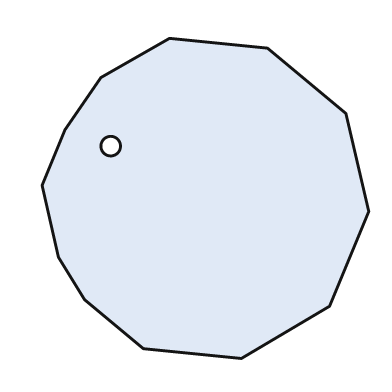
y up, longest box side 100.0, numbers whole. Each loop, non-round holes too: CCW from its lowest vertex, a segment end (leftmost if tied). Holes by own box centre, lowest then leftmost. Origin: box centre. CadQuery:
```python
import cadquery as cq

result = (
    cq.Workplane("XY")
    .moveTo(11.0, -49.0)
    .lineTo(38.0, -33.0)
    .lineTo(50.0, -4.0)
    .lineTo(43.0, 26.0)
    .lineTo(19.0, 46.0)
    .lineTo(-11.0, 49.0)
    .lineTo(-32.0, 37.0)
    .lineTo(-43.0, 21.0)
    .lineTo(-50.0, 4.0)
    .lineTo(-45.0, -18.0)
    .lineTo(-37.0, -31.0)
    .lineTo(-19.0, -46.0)
    .close()
    .moveTo(-29.0, 16.0)
    .circle(3.0)
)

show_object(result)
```